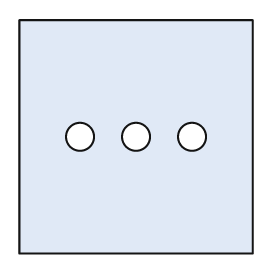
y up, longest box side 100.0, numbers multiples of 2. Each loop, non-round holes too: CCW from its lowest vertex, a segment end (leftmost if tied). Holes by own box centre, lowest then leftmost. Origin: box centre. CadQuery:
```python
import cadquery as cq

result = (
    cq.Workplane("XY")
    .moveTo(-50.0, -50.0)
    .lineTo(50.0, -50.0)
    .lineTo(50.0, 50.0)
    .lineTo(-50.0, 50.0)
    .close()
    .moveTo(-24.0, 0.0)
    .circle(6.0)
    .moveTo(0.0, 0.0)
    .circle(6.0)
    .moveTo(24.0, 0.0)
    .circle(6.0)
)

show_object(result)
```